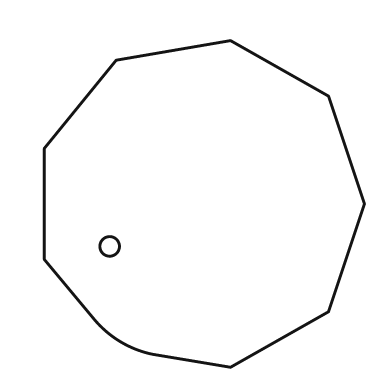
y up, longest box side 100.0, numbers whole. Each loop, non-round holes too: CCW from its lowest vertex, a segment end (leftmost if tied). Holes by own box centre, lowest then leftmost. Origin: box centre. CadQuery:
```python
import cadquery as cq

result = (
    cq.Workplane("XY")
    .moveTo(8.0, -50.0)
    .lineTo(38.0, -33.0)
    .lineTo(49.0, 0.0)
    .lineTo(38.0, 33.0)
    .lineTo(8.0, 50.0)
    .lineTo(-27.0, 44.0)
    .lineTo(-49.0, 17.0)
    .lineTo(-49.0, -17.0)
    .lineTo(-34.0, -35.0)
    .threePointArc((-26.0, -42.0), (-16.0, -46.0))
    .close()
    .moveTo(-29.0, -13.0)
    .circle(3.0)
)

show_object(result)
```